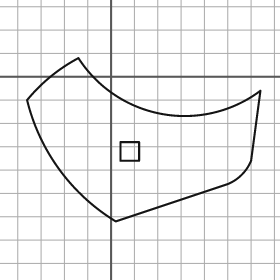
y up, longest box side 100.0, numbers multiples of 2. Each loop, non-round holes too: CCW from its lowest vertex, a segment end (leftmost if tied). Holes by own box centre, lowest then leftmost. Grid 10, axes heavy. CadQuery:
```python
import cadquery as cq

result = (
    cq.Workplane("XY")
    .moveTo(2.0, -62.0)
    .lineTo(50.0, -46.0)
    .threePointArc((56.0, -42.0), (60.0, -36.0))
    .lineTo(64.0, -6.0)
    .threePointArc((22.0, -16.0), (-14.0, 8.0))
    .threePointArc((-26.0, 0.0), (-36.0, -10.0))
    .threePointArc((-22.0, -40.0), (2.0, -62.0))
    .close()
    .moveTo(4.0, -36.0)
    .lineTo(12.0, -36.0)
    .lineTo(12.0, -28.0)
    .lineTo(4.0, -28.0)
    .close()
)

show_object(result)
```